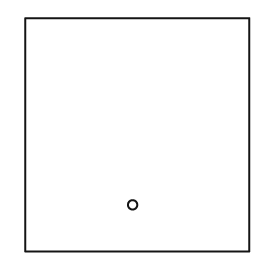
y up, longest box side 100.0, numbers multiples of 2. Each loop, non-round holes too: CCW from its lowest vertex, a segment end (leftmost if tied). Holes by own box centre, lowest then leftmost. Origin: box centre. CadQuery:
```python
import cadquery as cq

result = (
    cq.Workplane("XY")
    .moveTo(-48.0, -50.0)
    .lineTo(48.0, -50.0)
    .lineTo(48.0, 50.0)
    .lineTo(-48.0, 50.0)
    .close()
    .moveTo(-2.0, -30.0)
    .circle(2.0)
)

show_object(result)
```